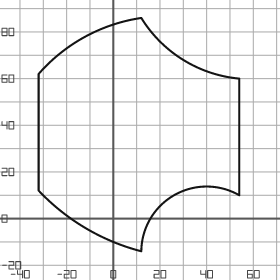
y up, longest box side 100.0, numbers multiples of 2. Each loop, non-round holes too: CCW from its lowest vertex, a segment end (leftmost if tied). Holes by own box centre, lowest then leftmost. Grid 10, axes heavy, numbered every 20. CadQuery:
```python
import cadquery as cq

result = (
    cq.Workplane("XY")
    .moveTo(12.0, -14.0)
    .threePointArc((26.0, 10.0), (54.0, 10.0))
    .lineTo(54.0, 60.0)
    .threePointArc((30.0, 68.0), (12.0, 86.0))
    .threePointArc((-12.0, 78.0), (-32.0, 62.0))
    .lineTo(-32.0, 12.0)
    .threePointArc((-12.0, -4.0), (12.0, -14.0))
    .close()
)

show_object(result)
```